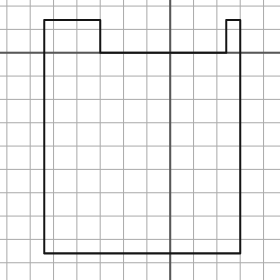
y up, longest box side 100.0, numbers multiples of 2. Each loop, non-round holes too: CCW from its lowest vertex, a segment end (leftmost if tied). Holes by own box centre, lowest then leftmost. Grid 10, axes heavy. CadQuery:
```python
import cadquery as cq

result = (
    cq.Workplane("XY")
    .moveTo(-54.0, -86.0)
    .lineTo(30.0, -86.0)
    .lineTo(30.0, 14.0)
    .lineTo(24.0, 14.0)
    .lineTo(24.0, 0.0)
    .lineTo(-30.0, 0.0)
    .lineTo(-30.0, 14.0)
    .lineTo(-54.0, 14.0)
    .close()
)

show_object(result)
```